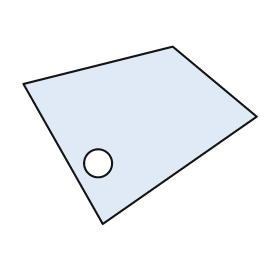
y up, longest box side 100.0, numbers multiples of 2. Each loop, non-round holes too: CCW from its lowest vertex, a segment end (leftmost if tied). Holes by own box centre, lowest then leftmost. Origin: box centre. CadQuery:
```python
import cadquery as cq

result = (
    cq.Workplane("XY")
    .moveTo(-16.0, -38.0)
    .lineTo(50.0, 8.0)
    .lineTo(14.0, 38.0)
    .lineTo(-50.0, 22.0)
    .close()
    .moveTo(-18.0, -12.0)
    .circle(6.0)
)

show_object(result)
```